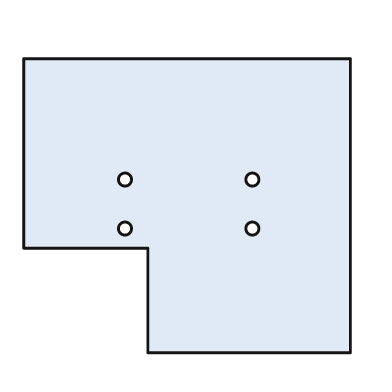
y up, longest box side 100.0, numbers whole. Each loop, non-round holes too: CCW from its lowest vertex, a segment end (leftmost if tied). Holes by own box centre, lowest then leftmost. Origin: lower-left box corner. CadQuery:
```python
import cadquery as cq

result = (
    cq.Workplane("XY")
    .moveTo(38.0, 0.0)
    .lineTo(100.0, 0.0)
    .lineTo(100.0, 90.0)
    .lineTo(0.0, 90.0)
    .lineTo(0.0, 32.0)
    .lineTo(38.0, 32.0)
    .close()
    .moveTo(31.0, 38.0)
    .circle(2.0)
    .moveTo(70.0, 38.0)
    .circle(2.0)
    .moveTo(31.0, 53.0)
    .circle(2.0)
    .moveTo(70.0, 53.0)
    .circle(2.0)
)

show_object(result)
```